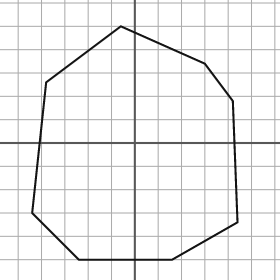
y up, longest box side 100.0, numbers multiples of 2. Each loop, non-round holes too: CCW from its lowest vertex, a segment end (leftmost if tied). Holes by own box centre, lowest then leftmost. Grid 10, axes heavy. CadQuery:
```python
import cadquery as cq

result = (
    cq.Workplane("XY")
    .moveTo(-24.0, -50.0)
    .lineTo(16.0, -50.0)
    .lineTo(44.0, -34.0)
    .lineTo(42.0, 18.0)
    .lineTo(30.0, 34.0)
    .lineTo(-6.0, 50.0)
    .lineTo(-38.0, 26.0)
    .lineTo(-44.0, -30.0)
    .close()
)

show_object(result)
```